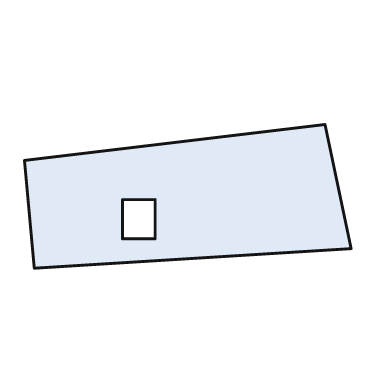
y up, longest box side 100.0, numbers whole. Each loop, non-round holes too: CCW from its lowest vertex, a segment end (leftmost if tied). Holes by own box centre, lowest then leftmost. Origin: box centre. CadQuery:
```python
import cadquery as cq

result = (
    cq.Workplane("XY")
    .moveTo(-47.0, -22.0)
    .lineTo(50.0, -16.0)
    .lineTo(42.0, 22.0)
    .lineTo(-50.0, 11.0)
    .close()
    .moveTo(-20.0, -13.0)
    .lineTo(-10.0, -13.0)
    .lineTo(-10.0, -1.0)
    .lineTo(-20.0, -1.0)
    .close()
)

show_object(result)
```